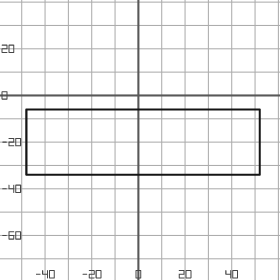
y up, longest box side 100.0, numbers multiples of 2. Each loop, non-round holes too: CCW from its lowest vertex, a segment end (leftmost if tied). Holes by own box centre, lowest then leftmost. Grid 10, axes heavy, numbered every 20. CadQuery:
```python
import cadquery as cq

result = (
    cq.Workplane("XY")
    .moveTo(-48.0, -34.0)
    .lineTo(52.0, -34.0)
    .lineTo(52.0, -6.0)
    .lineTo(-48.0, -6.0)
    .close()
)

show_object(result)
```